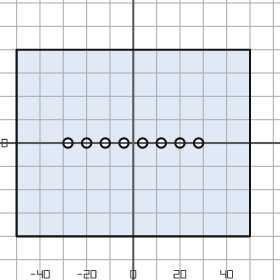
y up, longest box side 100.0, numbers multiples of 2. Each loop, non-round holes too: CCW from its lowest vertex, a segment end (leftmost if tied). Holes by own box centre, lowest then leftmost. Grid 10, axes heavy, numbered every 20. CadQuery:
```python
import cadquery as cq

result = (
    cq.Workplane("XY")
    .moveTo(-50.0, -40.0)
    .lineTo(50.0, -40.0)
    .lineTo(50.0, 40.0)
    .lineTo(-50.0, 40.0)
    .close()
    .moveTo(-28.0, 0.0)
    .circle(2.0)
    .moveTo(-20.0, 0.0)
    .circle(2.0)
    .moveTo(-12.0, 0.0)
    .circle(2.0)
    .moveTo(-4.0, 0.0)
    .circle(2.0)
    .moveTo(4.0, 0.0)
    .circle(2.0)
    .moveTo(12.0, 0.0)
    .circle(2.0)
    .moveTo(20.0, 0.0)
    .circle(2.0)
    .moveTo(28.0, 0.0)
    .circle(2.0)
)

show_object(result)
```